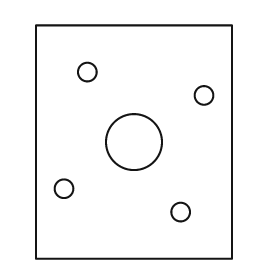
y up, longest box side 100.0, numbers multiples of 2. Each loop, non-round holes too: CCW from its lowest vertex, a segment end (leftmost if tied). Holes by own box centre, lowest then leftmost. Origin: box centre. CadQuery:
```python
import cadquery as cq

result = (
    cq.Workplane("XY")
    .moveTo(-42.0, -50.0)
    .lineTo(42.0, -50.0)
    .lineTo(42.0, 50.0)
    .lineTo(-42.0, 50.0)
    .close()
    .moveTo(20.0, -30.0)
    .circle(4.0)
    .moveTo(-30.0, -20.0)
    .circle(4.0)
    .moveTo(0.0, 0.0)
    .circle(12.0)
    .moveTo(30.0, 20.0)
    .circle(4.0)
    .moveTo(-20.0, 30.0)
    .circle(4.0)
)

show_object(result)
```